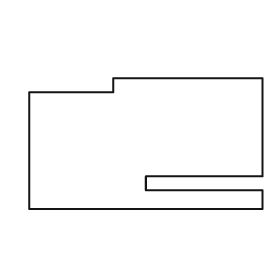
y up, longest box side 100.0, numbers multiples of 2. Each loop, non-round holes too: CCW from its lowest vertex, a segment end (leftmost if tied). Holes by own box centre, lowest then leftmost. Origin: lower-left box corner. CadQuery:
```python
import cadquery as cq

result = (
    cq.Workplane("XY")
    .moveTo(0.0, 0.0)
    .lineTo(100.0, 0.0)
    .lineTo(100.0, 8.0)
    .lineTo(50.0, 8.0)
    .lineTo(50.0, 14.0)
    .lineTo(100.0, 14.0)
    .lineTo(100.0, 56.0)
    .lineTo(36.0, 56.0)
    .lineTo(36.0, 50.0)
    .lineTo(0.0, 50.0)
    .close()
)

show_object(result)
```